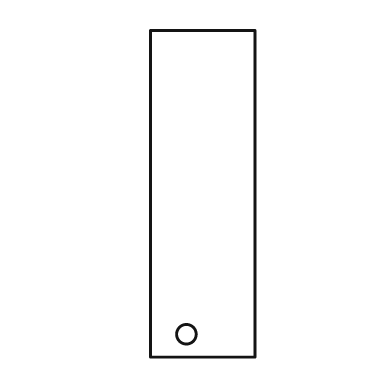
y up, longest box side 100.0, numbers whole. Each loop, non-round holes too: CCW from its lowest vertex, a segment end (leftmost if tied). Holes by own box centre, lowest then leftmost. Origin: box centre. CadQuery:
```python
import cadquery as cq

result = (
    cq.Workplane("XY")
    .moveTo(-16.0, -50.0)
    .lineTo(16.0, -50.0)
    .lineTo(16.0, 50.0)
    .lineTo(-16.0, 50.0)
    .close()
    .moveTo(-5.0, -43.0)
    .circle(3.0)
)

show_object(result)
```